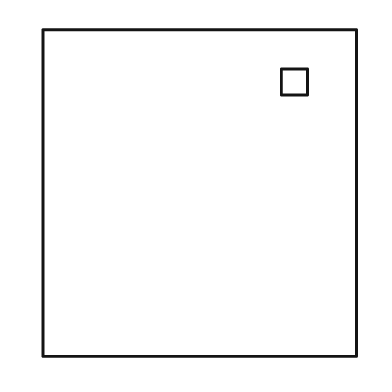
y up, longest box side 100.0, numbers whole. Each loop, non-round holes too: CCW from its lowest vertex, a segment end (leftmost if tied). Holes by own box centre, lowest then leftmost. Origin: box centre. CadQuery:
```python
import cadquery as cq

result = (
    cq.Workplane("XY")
    .moveTo(-48.0, -50.0)
    .lineTo(48.0, -50.0)
    .lineTo(48.0, 50.0)
    .lineTo(-48.0, 50.0)
    .close()
    .moveTo(25.0, 30.0)
    .lineTo(33.0, 30.0)
    .lineTo(33.0, 38.0)
    .lineTo(25.0, 38.0)
    .close()
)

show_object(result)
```